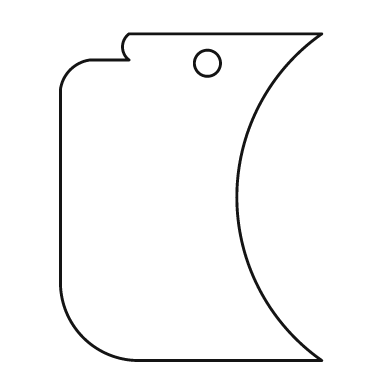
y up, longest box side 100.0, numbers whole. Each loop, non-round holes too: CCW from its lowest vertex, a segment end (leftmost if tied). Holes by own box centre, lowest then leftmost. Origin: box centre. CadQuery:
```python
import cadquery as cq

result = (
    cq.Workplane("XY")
    .moveTo(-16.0, -50.0)
    .lineTo(40.0, -50.0)
    .threePointArc((14.0, 0.0), (40.0, 50.0))
    .lineTo(-19.0, 50.0)
    .threePointArc((-21.0, 46.0), (-19.0, 42.0))
    .lineTo(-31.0, 42.0)
    .threePointArc((-37.0, 39.0), (-40.0, 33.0))
    .lineTo(-40.0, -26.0)
    .threePointArc((-33.0, -43.0), (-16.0, -50.0))
    .close()
    .moveTo(5.0, 41.0)
    .circle(4.0)
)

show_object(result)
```